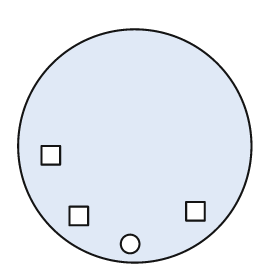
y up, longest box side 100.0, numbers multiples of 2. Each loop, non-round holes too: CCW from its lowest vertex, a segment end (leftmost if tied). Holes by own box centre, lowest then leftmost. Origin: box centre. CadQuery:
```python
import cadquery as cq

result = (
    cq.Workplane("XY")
    .moveTo(0.0, 0.0)
    .circle(50.0)
    .moveTo(-2.0, -42.0)
    .circle(4.0)
    .moveTo(-28.0, -34.0)
    .lineTo(-20.0, -34.0)
    .lineTo(-20.0, -26.0)
    .lineTo(-28.0, -26.0)
    .close()
    .moveTo(22.0, -32.0)
    .lineTo(30.0, -32.0)
    .lineTo(30.0, -24.0)
    .lineTo(22.0, -24.0)
    .close()
    .moveTo(-40.0, -8.0)
    .lineTo(-32.0, -8.0)
    .lineTo(-32.0, 0.0)
    .lineTo(-40.0, 0.0)
    .close()
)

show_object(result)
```